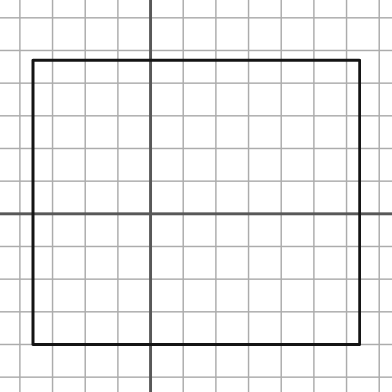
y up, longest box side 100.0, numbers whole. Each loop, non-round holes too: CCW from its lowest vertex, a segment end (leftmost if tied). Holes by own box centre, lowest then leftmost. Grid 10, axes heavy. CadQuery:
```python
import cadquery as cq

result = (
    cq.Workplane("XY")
    .moveTo(-36.0, -40.0)
    .lineTo(64.0, -40.0)
    .lineTo(64.0, 47.0)
    .lineTo(-36.0, 47.0)
    .close()
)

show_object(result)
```